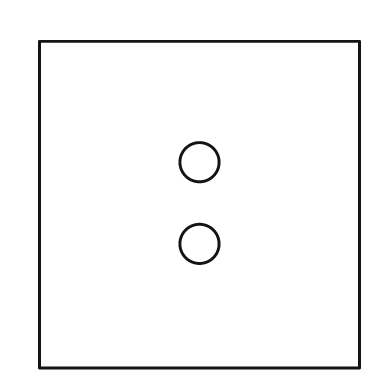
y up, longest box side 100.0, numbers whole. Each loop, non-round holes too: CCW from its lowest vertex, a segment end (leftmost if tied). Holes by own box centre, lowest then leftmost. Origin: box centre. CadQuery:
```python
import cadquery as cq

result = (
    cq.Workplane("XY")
    .moveTo(-49.0, -50.0)
    .lineTo(49.0, -50.0)
    .lineTo(49.0, 50.0)
    .lineTo(-49.0, 50.0)
    .close()
    .moveTo(0.0, -12.0)
    .circle(6.0)
    .moveTo(0.0, 13.0)
    .circle(6.0)
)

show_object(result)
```